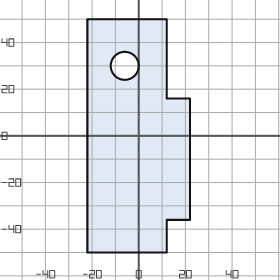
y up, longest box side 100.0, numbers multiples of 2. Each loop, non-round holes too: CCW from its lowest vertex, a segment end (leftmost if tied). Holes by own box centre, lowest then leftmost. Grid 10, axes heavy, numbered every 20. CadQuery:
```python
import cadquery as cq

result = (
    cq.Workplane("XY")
    .moveTo(-22.0, -50.0)
    .lineTo(12.0, -50.0)
    .lineTo(12.0, -36.0)
    .lineTo(22.0, -36.0)
    .lineTo(22.0, 16.0)
    .lineTo(12.0, 16.0)
    .lineTo(12.0, 50.0)
    .lineTo(-22.0, 50.0)
    .close()
    .moveTo(-6.0, 30.0)
    .circle(6.0)
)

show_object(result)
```